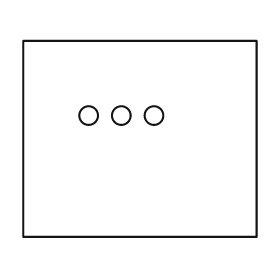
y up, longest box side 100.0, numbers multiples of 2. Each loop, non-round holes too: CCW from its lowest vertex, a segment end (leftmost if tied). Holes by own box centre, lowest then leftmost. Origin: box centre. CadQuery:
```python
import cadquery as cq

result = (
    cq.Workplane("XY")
    .moveTo(-50.0, -42.0)
    .lineTo(50.0, -42.0)
    .lineTo(50.0, 42.0)
    .lineTo(-50.0, 42.0)
    .close()
    .moveTo(-22.0, 10.0)
    .circle(4.0)
    .moveTo(-8.0, 10.0)
    .circle(4.0)
    .moveTo(6.0, 10.0)
    .circle(4.0)
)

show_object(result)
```